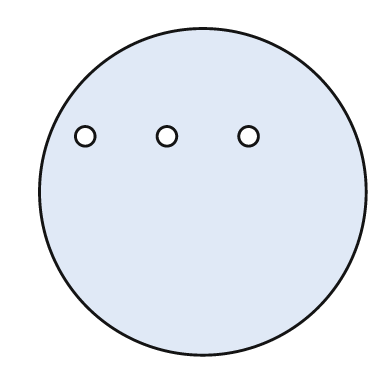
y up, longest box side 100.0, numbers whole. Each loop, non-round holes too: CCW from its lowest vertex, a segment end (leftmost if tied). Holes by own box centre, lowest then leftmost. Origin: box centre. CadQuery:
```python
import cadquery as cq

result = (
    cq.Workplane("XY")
    .moveTo(0.0, 0.0)
    .circle(50.0)
    .moveTo(-36.0, 17.0)
    .circle(3.0)
    .moveTo(-11.0, 17.0)
    .circle(3.0)
    .moveTo(14.0, 17.0)
    .circle(3.0)
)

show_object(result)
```